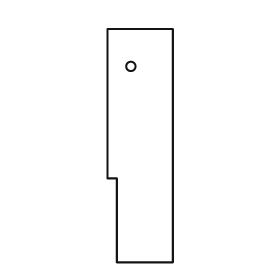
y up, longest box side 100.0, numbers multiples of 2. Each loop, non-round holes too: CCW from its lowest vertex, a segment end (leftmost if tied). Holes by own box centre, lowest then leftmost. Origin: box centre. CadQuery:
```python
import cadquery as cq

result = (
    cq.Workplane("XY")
    .moveTo(-10.0, -50.0)
    .lineTo(14.0, -50.0)
    .lineTo(14.0, 50.0)
    .lineTo(-14.0, 50.0)
    .lineTo(-14.0, -14.0)
    .lineTo(-10.0, -14.0)
    .close()
    .moveTo(-4.0, 34.0)
    .circle(2.0)
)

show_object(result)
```